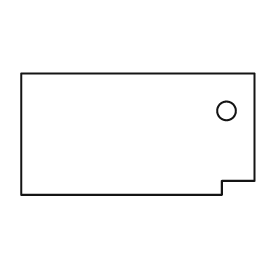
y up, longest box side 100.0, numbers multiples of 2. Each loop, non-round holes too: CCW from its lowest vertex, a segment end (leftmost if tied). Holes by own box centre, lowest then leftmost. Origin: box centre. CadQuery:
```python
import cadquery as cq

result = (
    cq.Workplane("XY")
    .moveTo(-50.0, -26.0)
    .lineTo(36.0, -26.0)
    .lineTo(36.0, -20.0)
    .lineTo(50.0, -20.0)
    .lineTo(50.0, 26.0)
    .lineTo(-50.0, 26.0)
    .close()
    .moveTo(38.0, 10.0)
    .circle(4.0)
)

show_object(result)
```